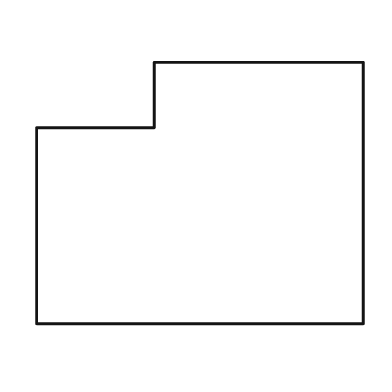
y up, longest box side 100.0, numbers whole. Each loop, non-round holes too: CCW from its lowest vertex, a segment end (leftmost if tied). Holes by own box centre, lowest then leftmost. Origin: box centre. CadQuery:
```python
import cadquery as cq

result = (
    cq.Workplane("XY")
    .moveTo(-50.0, -40.0)
    .lineTo(50.0, -40.0)
    .lineTo(50.0, 40.0)
    .lineTo(-14.0, 40.0)
    .lineTo(-14.0, 20.0)
    .lineTo(-50.0, 20.0)
    .close()
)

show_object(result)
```